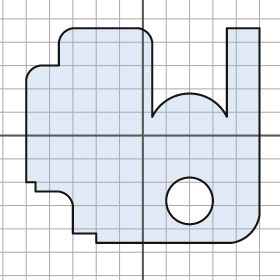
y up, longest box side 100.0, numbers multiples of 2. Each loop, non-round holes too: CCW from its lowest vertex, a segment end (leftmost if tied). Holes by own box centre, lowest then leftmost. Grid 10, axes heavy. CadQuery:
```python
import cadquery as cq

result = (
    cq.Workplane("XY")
    .moveTo(-20.0, -46.0)
    .lineTo(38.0, -46.0)
    .threePointArc((46.0, -42.0), (50.0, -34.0))
    .lineTo(50.0, 46.0)
    .lineTo(36.0, 46.0)
    .lineTo(36.0, 8.0)
    .threePointArc((20.0, 18.0), (4.0, 8.0))
    .lineTo(4.0, 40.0)
    .threePointArc((2.0, 44.0), (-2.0, 46.0))
    .lineTo(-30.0, 46.0)
    .threePointArc((-34.0, 44.0), (-36.0, 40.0))
    .lineTo(-36.0, 30.0)
    .lineTo(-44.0, 30.0)
    .threePointArc((-48.0, 28.0), (-50.0, 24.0))
    .lineTo(-50.0, -20.0)
    .lineTo(-46.0, -20.0)
    .lineTo(-46.0, -24.0)
    .lineTo(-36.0, -24.0)
    .threePointArc((-32.0, -26.0), (-30.0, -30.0))
    .lineTo(-30.0, -42.0)
    .lineTo(-20.0, -42.0)
    .close()
    .moveTo(20.0, -28.0)
    .circle(10.0)
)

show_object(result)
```